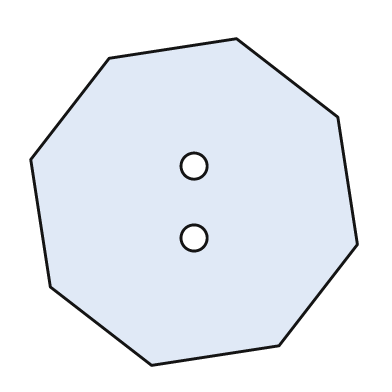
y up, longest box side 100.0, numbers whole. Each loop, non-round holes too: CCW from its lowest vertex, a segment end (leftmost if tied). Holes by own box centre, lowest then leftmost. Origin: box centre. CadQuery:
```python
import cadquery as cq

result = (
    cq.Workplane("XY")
    .moveTo(-13.0, -50.0)
    .lineTo(26.0, -44.0)
    .lineTo(50.0, -13.0)
    .lineTo(44.0, 26.0)
    .lineTo(13.0, 50.0)
    .lineTo(-26.0, 44.0)
    .lineTo(-50.0, 13.0)
    .lineTo(-44.0, -26.0)
    .close()
    .moveTo(0.0, -11.0)
    .circle(4.0)
    .moveTo(0.0, 11.0)
    .circle(4.0)
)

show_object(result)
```